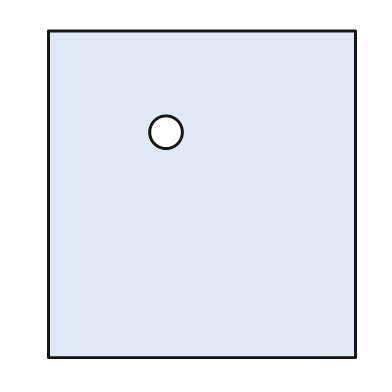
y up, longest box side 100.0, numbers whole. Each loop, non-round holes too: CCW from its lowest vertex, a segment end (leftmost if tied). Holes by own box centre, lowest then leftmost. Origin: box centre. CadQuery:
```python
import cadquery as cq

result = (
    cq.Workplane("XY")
    .moveTo(-47.0, -50.0)
    .lineTo(47.0, -50.0)
    .lineTo(47.0, 50.0)
    .lineTo(-47.0, 50.0)
    .close()
    .moveTo(-11.0, 19.0)
    .circle(5.0)
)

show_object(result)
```